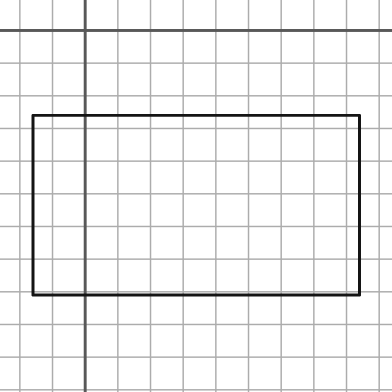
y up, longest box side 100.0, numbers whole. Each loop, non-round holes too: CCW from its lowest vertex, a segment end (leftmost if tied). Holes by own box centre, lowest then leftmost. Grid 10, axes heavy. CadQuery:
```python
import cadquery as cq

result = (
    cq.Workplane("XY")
    .moveTo(-16.0, -81.0)
    .lineTo(84.0, -81.0)
    .lineTo(84.0, -26.0)
    .lineTo(-16.0, -26.0)
    .close()
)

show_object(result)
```